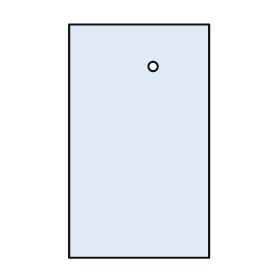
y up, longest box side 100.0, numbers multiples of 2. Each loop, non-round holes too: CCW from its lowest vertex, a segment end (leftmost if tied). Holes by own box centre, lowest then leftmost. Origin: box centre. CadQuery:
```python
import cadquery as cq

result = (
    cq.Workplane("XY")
    .moveTo(-30.0, -50.0)
    .lineTo(30.0, -50.0)
    .lineTo(30.0, 50.0)
    .lineTo(-30.0, 50.0)
    .close()
    .moveTo(6.0, 32.0)
    .circle(2.0)
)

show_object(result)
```